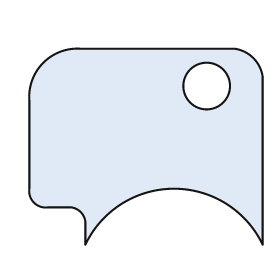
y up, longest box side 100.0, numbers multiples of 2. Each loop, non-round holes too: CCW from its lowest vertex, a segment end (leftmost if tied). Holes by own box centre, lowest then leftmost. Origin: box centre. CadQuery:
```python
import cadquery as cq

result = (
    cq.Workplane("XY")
    .moveTo(-26.0, -42.0)
    .threePointArc((12.0, -18.0), (50.0, -42.0))
    .lineTo(50.0, 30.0)
    .threePointArc((46.0, 38.0), (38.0, 42.0))
    .lineTo(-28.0, 42.0)
    .threePointArc((-44.0, 36.0), (-50.0, 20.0))
    .lineTo(-50.0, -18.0)
    .threePointArc((-48.0, -24.0), (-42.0, -26.0))
    .lineTo(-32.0, -26.0)
    .threePointArc((-28.0, -28.0), (-26.0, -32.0))
    .close()
    .moveTo(26.0, 26.0)
    .circle(10.0)
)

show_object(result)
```